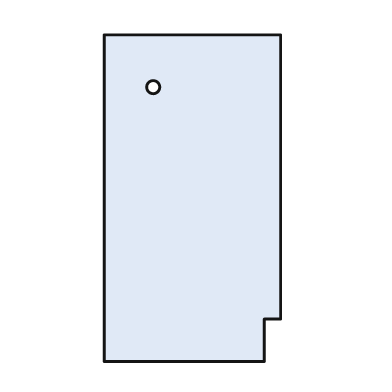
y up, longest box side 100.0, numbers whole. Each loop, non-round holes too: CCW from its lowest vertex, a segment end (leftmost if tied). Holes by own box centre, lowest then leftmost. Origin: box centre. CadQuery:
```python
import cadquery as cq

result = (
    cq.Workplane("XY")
    .moveTo(-27.0, -50.0)
    .lineTo(22.0, -50.0)
    .lineTo(22.0, -37.0)
    .lineTo(27.0, -37.0)
    .lineTo(27.0, 50.0)
    .lineTo(-27.0, 50.0)
    .close()
    .moveTo(-12.0, 34.0)
    .circle(2.0)
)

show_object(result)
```